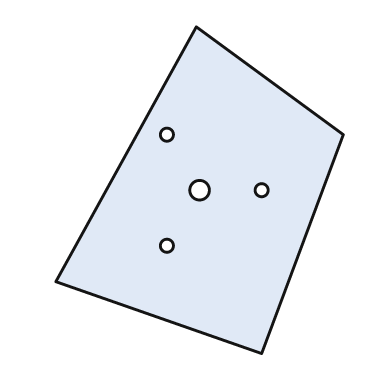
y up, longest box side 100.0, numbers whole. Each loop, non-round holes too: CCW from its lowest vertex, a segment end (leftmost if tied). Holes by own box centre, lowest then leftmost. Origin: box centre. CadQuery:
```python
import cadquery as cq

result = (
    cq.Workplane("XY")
    .moveTo(19.0, -50.0)
    .lineTo(44.0, 17.0)
    .lineTo(-1.0, 50.0)
    .lineTo(-44.0, -28.0)
    .close()
    .moveTo(-10.0, -17.0)
    .circle(2.0)
    .moveTo(0.0, 0.0)
    .circle(3.0)
    .moveTo(19.0, 0.0)
    .circle(2.0)
    .moveTo(-10.0, 17.0)
    .circle(2.0)
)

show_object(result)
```